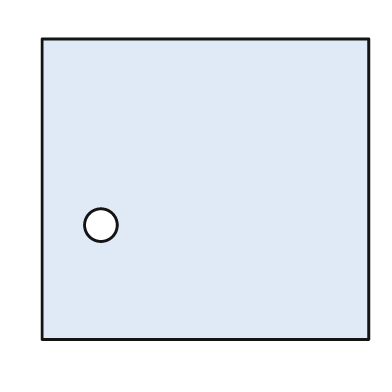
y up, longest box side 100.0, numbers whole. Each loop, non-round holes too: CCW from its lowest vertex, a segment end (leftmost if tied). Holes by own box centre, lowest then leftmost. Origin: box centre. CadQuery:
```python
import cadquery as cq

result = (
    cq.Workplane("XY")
    .moveTo(-50.0, -46.0)
    .lineTo(50.0, -46.0)
    .lineTo(50.0, 46.0)
    .lineTo(-50.0, 46.0)
    .close()
    .moveTo(-32.0, -11.0)
    .circle(5.0)
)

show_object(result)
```